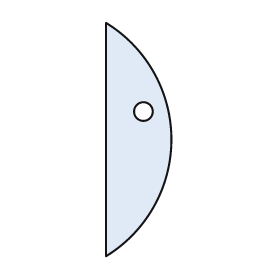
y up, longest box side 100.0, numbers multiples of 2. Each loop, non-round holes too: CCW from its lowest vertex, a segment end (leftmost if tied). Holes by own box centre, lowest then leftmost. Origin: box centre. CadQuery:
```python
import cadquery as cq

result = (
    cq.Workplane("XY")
    .moveTo(-14.0, -50.0)
    .threePointArc((14.0, 0.0), (-14.0, 50.0))
    .close()
    .moveTo(2.0, 12.0)
    .circle(4.0)
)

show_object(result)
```